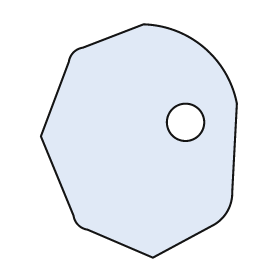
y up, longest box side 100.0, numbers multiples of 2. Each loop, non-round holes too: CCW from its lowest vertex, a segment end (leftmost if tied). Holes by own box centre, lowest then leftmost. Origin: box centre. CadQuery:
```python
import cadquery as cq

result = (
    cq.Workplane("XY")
    .moveTo(6.0, -50.0)
    .lineTo(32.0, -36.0)
    .threePointArc((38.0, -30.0), (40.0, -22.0))
    .lineTo(42.0, 16.0)
    .threePointArc((28.0, 40.0), (2.0, 50.0))
    .lineTo(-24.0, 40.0)
    .threePointArc((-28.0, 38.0), (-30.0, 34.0))
    .lineTo(-42.0, 2.0)
    .lineTo(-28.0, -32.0)
    .threePointArc((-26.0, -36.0), (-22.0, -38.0))
    .close()
    .moveTo(20.0, 8.0)
    .circle(8.0)
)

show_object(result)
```